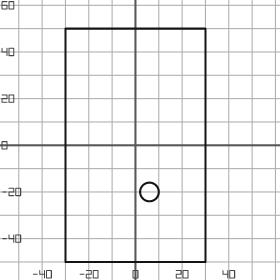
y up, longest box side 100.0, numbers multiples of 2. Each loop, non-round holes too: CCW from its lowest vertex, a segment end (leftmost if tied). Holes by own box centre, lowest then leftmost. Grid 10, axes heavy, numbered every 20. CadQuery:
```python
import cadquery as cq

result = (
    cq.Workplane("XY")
    .moveTo(-30.0, -50.0)
    .lineTo(30.0, -50.0)
    .lineTo(30.0, 50.0)
    .lineTo(-30.0, 50.0)
    .close()
    .moveTo(6.0, -20.0)
    .circle(4.0)
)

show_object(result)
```